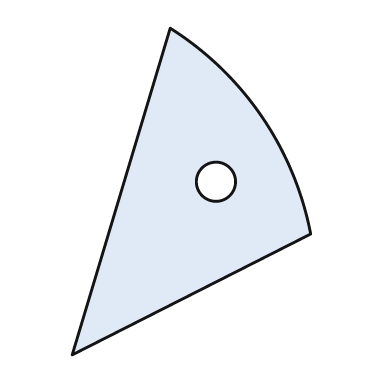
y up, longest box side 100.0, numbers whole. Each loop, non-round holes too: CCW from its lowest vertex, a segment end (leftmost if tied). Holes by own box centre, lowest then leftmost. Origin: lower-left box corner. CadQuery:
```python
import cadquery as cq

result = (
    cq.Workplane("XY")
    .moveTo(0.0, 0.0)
    .lineTo(73.0, 37.0)
    .threePointArc((58.0, 73.0), (30.0, 100.0))
    .close()
    .moveTo(44.0, 53.0)
    .circle(6.0)
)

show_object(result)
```